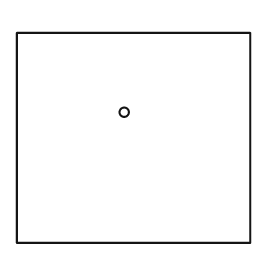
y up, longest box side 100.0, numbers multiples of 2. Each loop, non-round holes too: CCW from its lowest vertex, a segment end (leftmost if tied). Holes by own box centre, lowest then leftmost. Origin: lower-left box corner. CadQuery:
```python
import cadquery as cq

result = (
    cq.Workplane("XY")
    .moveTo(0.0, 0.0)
    .lineTo(100.0, 0.0)
    .lineTo(100.0, 90.0)
    .lineTo(0.0, 90.0)
    .close()
    .moveTo(46.0, 56.0)
    .circle(2.0)
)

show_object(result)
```